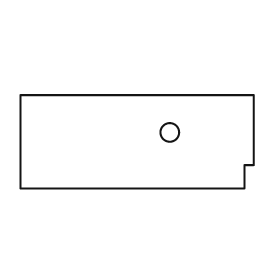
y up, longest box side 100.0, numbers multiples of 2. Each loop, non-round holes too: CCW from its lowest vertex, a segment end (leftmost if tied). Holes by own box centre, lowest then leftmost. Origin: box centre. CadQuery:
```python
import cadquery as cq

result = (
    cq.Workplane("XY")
    .moveTo(-50.0, -20.0)
    .lineTo(46.0, -20.0)
    .lineTo(46.0, -10.0)
    .lineTo(50.0, -10.0)
    .lineTo(50.0, 20.0)
    .lineTo(-50.0, 20.0)
    .close()
    .moveTo(14.0, 4.0)
    .circle(4.0)
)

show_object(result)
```